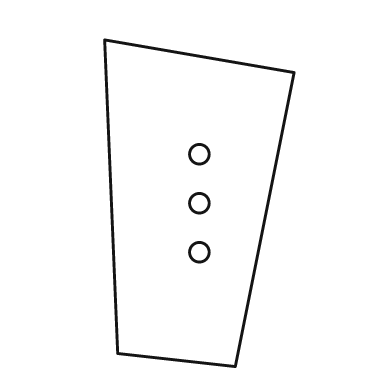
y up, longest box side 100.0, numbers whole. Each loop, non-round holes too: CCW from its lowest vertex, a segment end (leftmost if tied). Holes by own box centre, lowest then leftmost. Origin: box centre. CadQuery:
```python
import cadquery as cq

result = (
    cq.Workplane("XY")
    .moveTo(11.0, -50.0)
    .lineTo(29.0, 40.0)
    .lineTo(-29.0, 50.0)
    .lineTo(-25.0, -46.0)
    .close()
    .moveTo(0.0, -15.0)
    .circle(3.0)
    .moveTo(0.0, 0.0)
    .circle(3.0)
    .moveTo(0.0, 15.0)
    .circle(3.0)
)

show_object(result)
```